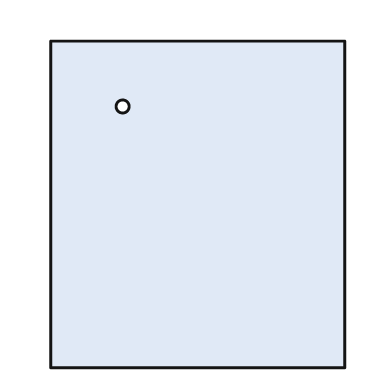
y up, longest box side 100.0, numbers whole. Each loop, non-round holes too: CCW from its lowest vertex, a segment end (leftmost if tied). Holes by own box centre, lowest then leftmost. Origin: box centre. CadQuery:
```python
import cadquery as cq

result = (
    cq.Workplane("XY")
    .moveTo(-45.0, -50.0)
    .lineTo(45.0, -50.0)
    .lineTo(45.0, 50.0)
    .lineTo(-45.0, 50.0)
    .close()
    .moveTo(-23.0, 30.0)
    .circle(2.0)
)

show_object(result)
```